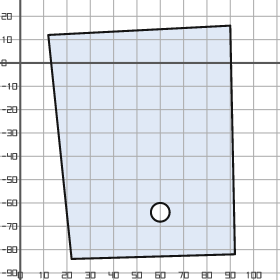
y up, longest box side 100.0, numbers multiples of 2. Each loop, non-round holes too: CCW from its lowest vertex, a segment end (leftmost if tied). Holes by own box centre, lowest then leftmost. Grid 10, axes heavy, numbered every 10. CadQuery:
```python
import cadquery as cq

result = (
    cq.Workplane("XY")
    .moveTo(22.0, -84.0)
    .lineTo(92.0, -82.0)
    .lineTo(90.0, 16.0)
    .lineTo(12.0, 12.0)
    .close()
    .moveTo(60.0, -64.0)
    .circle(4.0)
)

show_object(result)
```